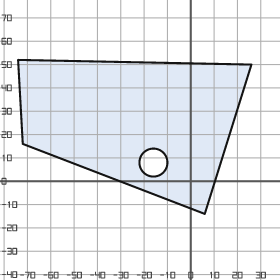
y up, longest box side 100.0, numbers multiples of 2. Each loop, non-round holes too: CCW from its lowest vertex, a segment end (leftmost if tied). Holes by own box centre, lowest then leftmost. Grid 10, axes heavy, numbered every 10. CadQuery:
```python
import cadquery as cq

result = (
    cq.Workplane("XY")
    .moveTo(6.0, -14.0)
    .lineTo(26.0, 50.0)
    .lineTo(-74.0, 52.0)
    .lineTo(-72.0, 16.0)
    .close()
    .moveTo(-16.0, 8.0)
    .circle(6.0)
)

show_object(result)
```